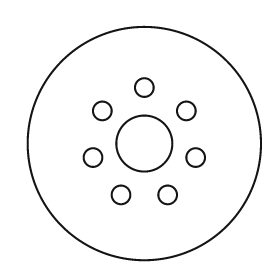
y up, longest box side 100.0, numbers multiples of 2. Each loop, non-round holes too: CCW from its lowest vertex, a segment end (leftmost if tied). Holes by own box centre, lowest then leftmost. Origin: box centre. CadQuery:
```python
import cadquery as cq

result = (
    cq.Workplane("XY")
    .moveTo(0.0, 0.0)
    .circle(50.0)
    .moveTo(-10.0, -22.0)
    .circle(4.0)
    .moveTo(10.0, -22.0)
    .circle(4.0)
    .moveTo(-22.0, -6.0)
    .circle(4.0)
    .moveTo(22.0, -6.0)
    .circle(4.0)
    .moveTo(0.0, 0.0)
    .circle(12.0)
    .moveTo(-18.0, 14.0)
    .circle(4.0)
    .moveTo(18.0, 14.0)
    .circle(4.0)
    .moveTo(0.0, 24.0)
    .circle(4.0)
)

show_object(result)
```